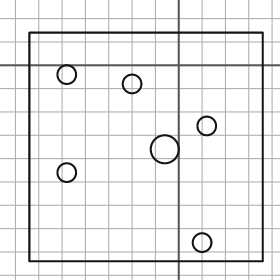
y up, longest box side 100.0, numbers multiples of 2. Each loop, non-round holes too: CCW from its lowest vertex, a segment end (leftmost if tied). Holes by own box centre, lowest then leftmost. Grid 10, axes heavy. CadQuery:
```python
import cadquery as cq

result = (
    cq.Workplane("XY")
    .moveTo(-64.0, -84.0)
    .lineTo(36.0, -84.0)
    .lineTo(36.0, 14.0)
    .lineTo(-64.0, 14.0)
    .close()
    .moveTo(10.0, -76.0)
    .circle(4.0)
    .moveTo(-48.0, -46.0)
    .circle(4.0)
    .moveTo(-6.0, -36.0)
    .circle(6.0)
    .moveTo(12.0, -26.0)
    .circle(4.0)
    .moveTo(-20.0, -8.0)
    .circle(4.0)
    .moveTo(-48.0, -4.0)
    .circle(4.0)
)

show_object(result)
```